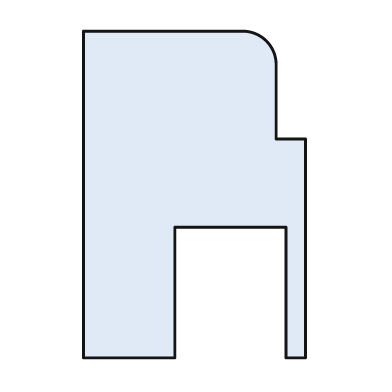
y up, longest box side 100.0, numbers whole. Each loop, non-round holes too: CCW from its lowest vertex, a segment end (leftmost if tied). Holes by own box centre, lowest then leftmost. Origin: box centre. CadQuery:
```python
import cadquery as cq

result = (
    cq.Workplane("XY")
    .moveTo(-34.0, -50.0)
    .lineTo(-6.0, -50.0)
    .lineTo(-6.0, -10.0)
    .lineTo(28.0, -10.0)
    .lineTo(28.0, -50.0)
    .lineTo(34.0, -50.0)
    .lineTo(34.0, 17.0)
    .lineTo(25.0, 17.0)
    .lineTo(25.0, 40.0)
    .threePointArc((22.0, 47.0), (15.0, 50.0))
    .lineTo(-34.0, 50.0)
    .close()
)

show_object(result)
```